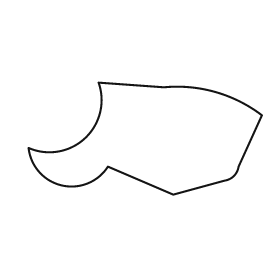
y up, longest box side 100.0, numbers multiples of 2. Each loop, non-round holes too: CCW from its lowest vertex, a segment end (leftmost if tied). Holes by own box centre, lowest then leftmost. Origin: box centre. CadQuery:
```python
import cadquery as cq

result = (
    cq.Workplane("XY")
    .moveTo(12.0, -24.0)
    .lineTo(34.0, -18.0)
    .threePointArc((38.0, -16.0), (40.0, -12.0))
    .lineTo(50.0, 10.0)
    .threePointArc((30.0, 20.0), (8.0, 22.0))
    .lineTo(-20.0, 24.0)
    .threePointArc((-26.0, 0.0), (-50.0, -4.0))
    .threePointArc((-36.0, -20.0), (-16.0, -12.0))
    .close()
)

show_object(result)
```